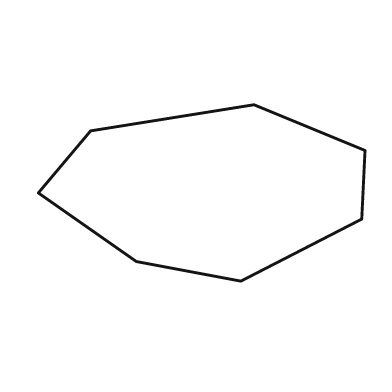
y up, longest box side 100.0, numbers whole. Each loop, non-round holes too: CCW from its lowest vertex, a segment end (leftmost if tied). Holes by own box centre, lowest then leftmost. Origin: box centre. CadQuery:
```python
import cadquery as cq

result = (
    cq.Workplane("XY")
    .moveTo(12.0, -27.0)
    .lineTo(49.0, -8.0)
    .lineTo(50.0, 13.0)
    .lineTo(16.0, 27.0)
    .lineTo(-34.0, 19.0)
    .lineTo(-50.0, 0.0)
    .lineTo(-20.0, -21.0)
    .close()
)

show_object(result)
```